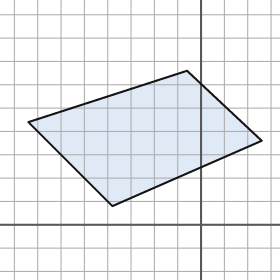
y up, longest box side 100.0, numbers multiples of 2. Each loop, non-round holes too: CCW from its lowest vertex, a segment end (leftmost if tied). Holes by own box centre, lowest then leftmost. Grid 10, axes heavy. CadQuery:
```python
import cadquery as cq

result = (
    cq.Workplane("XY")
    .moveTo(-38.0, 8.0)
    .lineTo(26.0, 36.0)
    .lineTo(-6.0, 66.0)
    .lineTo(-74.0, 44.0)
    .close()
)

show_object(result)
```